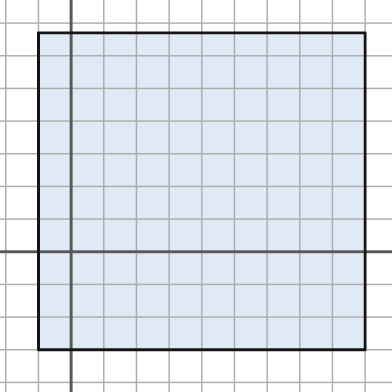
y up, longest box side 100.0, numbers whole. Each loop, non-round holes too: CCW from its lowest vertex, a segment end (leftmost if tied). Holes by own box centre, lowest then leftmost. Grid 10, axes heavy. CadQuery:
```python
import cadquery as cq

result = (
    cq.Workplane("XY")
    .moveTo(-10.0, -30.0)
    .lineTo(90.0, -30.0)
    .lineTo(90.0, 67.0)
    .lineTo(-10.0, 67.0)
    .close()
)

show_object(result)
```